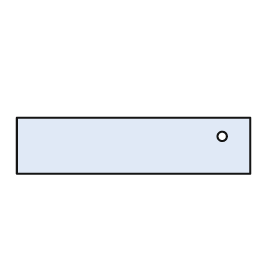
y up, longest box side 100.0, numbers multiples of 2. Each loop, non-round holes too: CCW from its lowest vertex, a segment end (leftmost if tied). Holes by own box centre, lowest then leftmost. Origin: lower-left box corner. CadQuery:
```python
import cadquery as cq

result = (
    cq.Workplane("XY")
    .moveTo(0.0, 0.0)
    .lineTo(100.0, 0.0)
    .lineTo(100.0, 24.0)
    .lineTo(0.0, 24.0)
    .close()
    .moveTo(88.0, 16.0)
    .circle(2.0)
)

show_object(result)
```